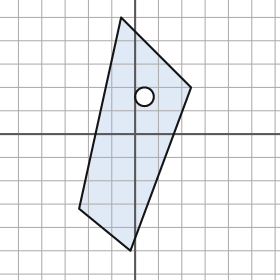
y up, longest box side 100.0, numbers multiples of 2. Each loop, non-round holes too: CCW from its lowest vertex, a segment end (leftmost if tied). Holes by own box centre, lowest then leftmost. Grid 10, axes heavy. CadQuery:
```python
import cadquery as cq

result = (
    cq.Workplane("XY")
    .moveTo(-2.0, -50.0)
    .lineTo(24.0, 20.0)
    .lineTo(-6.0, 50.0)
    .lineTo(-24.0, -32.0)
    .close()
    .moveTo(4.0, 16.0)
    .circle(4.0)
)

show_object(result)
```